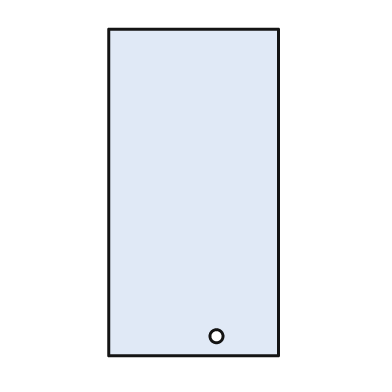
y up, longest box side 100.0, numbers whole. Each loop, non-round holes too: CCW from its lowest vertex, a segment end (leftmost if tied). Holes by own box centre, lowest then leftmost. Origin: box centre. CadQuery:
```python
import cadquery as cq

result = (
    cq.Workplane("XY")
    .moveTo(-26.0, -50.0)
    .lineTo(26.0, -50.0)
    .lineTo(26.0, 50.0)
    .lineTo(-26.0, 50.0)
    .close()
    .moveTo(7.0, -44.0)
    .circle(2.0)
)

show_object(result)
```